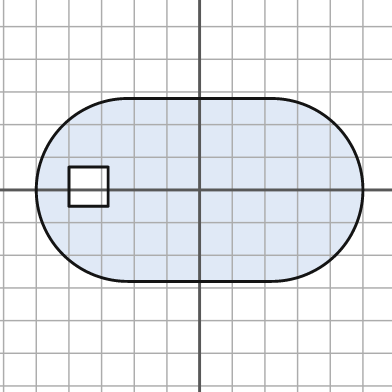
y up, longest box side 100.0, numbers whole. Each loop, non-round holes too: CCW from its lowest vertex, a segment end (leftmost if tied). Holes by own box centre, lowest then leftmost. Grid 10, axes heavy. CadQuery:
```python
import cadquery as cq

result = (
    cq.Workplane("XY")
    .moveTo(-22.0, -28.0)
    .lineTo(22.0, -28.0)
    .threePointArc((50.0, 0.0), (22.0, 28.0))
    .lineTo(-22.0, 28.0)
    .threePointArc((-50.0, 0.0), (-22.0, -28.0))
    .close()
    .moveTo(-40.0, -5.0)
    .lineTo(-28.0, -5.0)
    .lineTo(-28.0, 7.0)
    .lineTo(-40.0, 7.0)
    .close()
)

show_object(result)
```